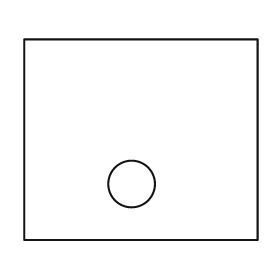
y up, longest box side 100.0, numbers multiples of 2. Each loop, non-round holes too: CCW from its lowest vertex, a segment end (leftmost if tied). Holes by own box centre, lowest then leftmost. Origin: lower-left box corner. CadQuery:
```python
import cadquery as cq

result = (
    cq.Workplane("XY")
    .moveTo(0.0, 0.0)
    .lineTo(100.0, 0.0)
    .lineTo(100.0, 86.0)
    .lineTo(0.0, 86.0)
    .close()
    .moveTo(46.0, 24.0)
    .circle(10.0)
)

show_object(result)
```